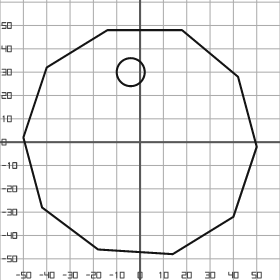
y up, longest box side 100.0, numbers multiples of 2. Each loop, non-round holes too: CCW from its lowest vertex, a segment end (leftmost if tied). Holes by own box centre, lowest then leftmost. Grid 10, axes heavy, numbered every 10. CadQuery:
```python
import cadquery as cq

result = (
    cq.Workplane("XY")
    .moveTo(14.0, -48.0)
    .lineTo(40.0, -32.0)
    .lineTo(50.0, -2.0)
    .lineTo(42.0, 28.0)
    .lineTo(18.0, 48.0)
    .lineTo(-14.0, 48.0)
    .lineTo(-40.0, 32.0)
    .lineTo(-50.0, 2.0)
    .lineTo(-42.0, -28.0)
    .lineTo(-18.0, -46.0)
    .close()
    .moveTo(-4.0, 30.0)
    .circle(6.0)
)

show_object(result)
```